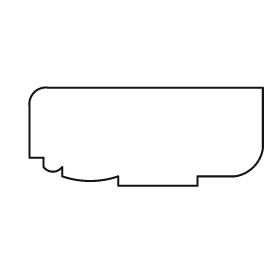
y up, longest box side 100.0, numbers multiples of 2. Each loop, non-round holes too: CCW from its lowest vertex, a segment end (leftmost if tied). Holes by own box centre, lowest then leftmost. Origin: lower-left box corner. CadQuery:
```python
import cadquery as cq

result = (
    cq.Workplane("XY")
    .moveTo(38.0, 0.0)
    .lineTo(72.0, 0.0)
    .lineTo(72.0, 4.0)
    .lineTo(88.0, 4.0)
    .threePointArc((96.0, 8.0), (100.0, 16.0))
    .lineTo(100.0, 42.0)
    .lineTo(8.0, 42.0)
    .threePointArc((2.0, 40.0), (0.0, 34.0))
    .lineTo(0.0, 12.0)
    .lineTo(6.0, 12.0)
    .lineTo(6.0, 8.0)
    .threePointArc((10.0, 6.0), (14.0, 8.0))
    .lineTo(14.0, 4.0)
    .threePointArc((26.0, 2.0), (38.0, 4.0))
    .close()
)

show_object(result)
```